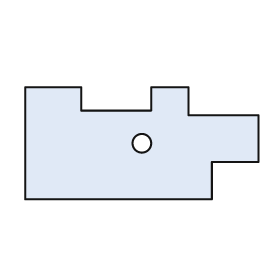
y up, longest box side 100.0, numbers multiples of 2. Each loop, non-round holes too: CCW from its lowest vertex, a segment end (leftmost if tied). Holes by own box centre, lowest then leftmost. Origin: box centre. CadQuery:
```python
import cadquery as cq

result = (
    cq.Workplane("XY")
    .moveTo(-50.0, -24.0)
    .lineTo(30.0, -24.0)
    .lineTo(30.0, -8.0)
    .lineTo(50.0, -8.0)
    .lineTo(50.0, 12.0)
    .lineTo(20.0, 12.0)
    .lineTo(20.0, 24.0)
    .lineTo(4.0, 24.0)
    .lineTo(4.0, 14.0)
    .lineTo(-26.0, 14.0)
    .lineTo(-26.0, 24.0)
    .lineTo(-50.0, 24.0)
    .close()
    .moveTo(0.0, 0.0)
    .circle(4.0)
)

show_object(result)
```